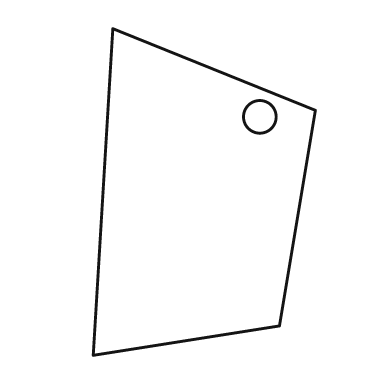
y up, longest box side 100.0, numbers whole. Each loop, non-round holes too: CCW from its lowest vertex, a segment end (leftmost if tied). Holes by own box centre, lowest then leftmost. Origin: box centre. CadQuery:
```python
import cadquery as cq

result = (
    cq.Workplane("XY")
    .moveTo(-34.0, -50.0)
    .lineTo(23.0, -41.0)
    .lineTo(34.0, 25.0)
    .lineTo(-28.0, 50.0)
    .close()
    .moveTo(17.0, 23.0)
    .circle(5.0)
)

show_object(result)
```